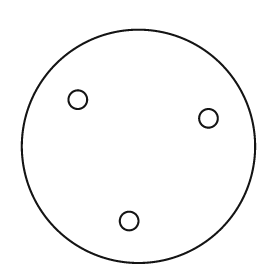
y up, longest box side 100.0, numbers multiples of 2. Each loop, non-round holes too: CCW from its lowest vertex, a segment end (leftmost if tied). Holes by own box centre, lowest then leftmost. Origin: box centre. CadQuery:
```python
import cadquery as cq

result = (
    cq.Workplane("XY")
    .moveTo(0.0, 0.0)
    .circle(50.0)
    .moveTo(-4.0, -32.0)
    .circle(4.0)
    .moveTo(30.0, 12.0)
    .circle(4.0)
    .moveTo(-26.0, 20.0)
    .circle(4.0)
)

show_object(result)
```